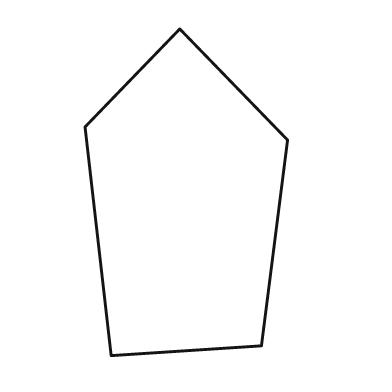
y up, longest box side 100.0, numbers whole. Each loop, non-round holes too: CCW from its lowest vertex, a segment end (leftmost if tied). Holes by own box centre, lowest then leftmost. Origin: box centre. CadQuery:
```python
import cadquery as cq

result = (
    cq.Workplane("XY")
    .moveTo(-23.0, -50.0)
    .lineTo(23.0, -47.0)
    .lineTo(31.0, 16.0)
    .lineTo(-2.0, 50.0)
    .lineTo(-31.0, 20.0)
    .close()
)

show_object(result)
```